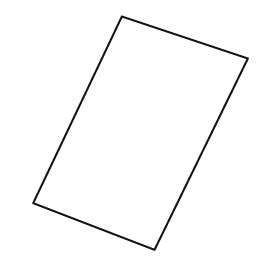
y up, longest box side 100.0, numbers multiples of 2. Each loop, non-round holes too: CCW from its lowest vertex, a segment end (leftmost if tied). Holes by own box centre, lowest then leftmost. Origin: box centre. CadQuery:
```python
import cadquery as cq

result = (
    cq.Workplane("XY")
    .moveTo(6.0, -50.0)
    .lineTo(46.0, 32.0)
    .lineTo(-8.0, 50.0)
    .lineTo(-46.0, -30.0)
    .close()
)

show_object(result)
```